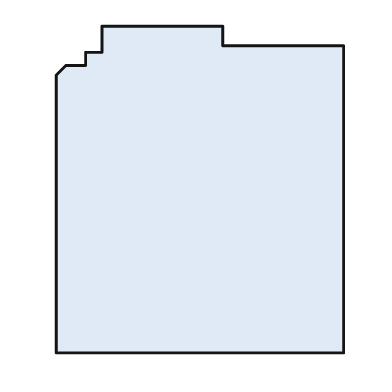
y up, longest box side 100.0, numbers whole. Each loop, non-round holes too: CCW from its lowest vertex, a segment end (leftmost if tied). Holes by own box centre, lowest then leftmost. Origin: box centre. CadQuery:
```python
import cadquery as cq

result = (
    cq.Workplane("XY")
    .moveTo(-44.0, -50.0)
    .lineTo(44.0, -50.0)
    .lineTo(44.0, 44.0)
    .lineTo(7.0, 44.0)
    .lineTo(7.0, 50.0)
    .lineTo(-30.0, 50.0)
    .lineTo(-30.0, 42.0)
    .lineTo(-35.0, 42.0)
    .lineTo(-35.0, 38.0)
    .lineTo(-41.0, 38.0)
    .lineTo(-44.0, 35.0)
    .close()
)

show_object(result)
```